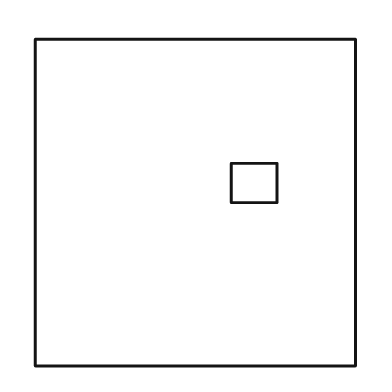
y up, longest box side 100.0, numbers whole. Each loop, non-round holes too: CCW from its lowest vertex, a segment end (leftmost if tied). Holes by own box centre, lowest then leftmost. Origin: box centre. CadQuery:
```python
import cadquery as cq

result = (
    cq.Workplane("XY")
    .moveTo(-49.0, -50.0)
    .lineTo(49.0, -50.0)
    .lineTo(49.0, 50.0)
    .lineTo(-49.0, 50.0)
    .close()
    .moveTo(11.0, 0.0)
    .lineTo(25.0, 0.0)
    .lineTo(25.0, 12.0)
    .lineTo(11.0, 12.0)
    .close()
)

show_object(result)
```